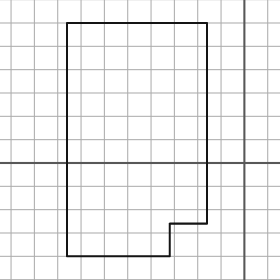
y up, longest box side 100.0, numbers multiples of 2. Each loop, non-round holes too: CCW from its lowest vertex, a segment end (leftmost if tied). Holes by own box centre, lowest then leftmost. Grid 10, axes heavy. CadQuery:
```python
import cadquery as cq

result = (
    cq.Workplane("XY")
    .moveTo(-76.0, -40.0)
    .lineTo(-32.0, -40.0)
    .lineTo(-32.0, -26.0)
    .lineTo(-16.0, -26.0)
    .lineTo(-16.0, 60.0)
    .lineTo(-76.0, 60.0)
    .close()
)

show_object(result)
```